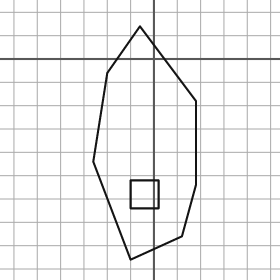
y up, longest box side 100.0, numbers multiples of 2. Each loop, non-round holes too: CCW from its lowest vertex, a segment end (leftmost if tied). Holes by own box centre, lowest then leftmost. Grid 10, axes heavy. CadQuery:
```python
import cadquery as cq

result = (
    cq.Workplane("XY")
    .moveTo(-10.0, -86.0)
    .lineTo(12.0, -76.0)
    .lineTo(18.0, -54.0)
    .lineTo(18.0, -18.0)
    .lineTo(-6.0, 14.0)
    .lineTo(-20.0, -6.0)
    .lineTo(-26.0, -44.0)
    .close()
    .moveTo(-10.0, -64.0)
    .lineTo(2.0, -64.0)
    .lineTo(2.0, -52.0)
    .lineTo(-10.0, -52.0)
    .close()
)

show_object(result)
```